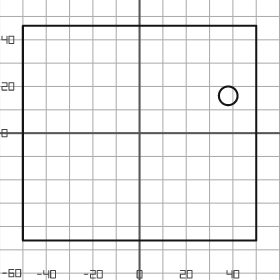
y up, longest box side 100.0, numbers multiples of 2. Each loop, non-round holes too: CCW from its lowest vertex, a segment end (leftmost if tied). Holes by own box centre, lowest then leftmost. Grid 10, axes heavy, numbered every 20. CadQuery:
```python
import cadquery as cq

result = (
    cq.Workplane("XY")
    .moveTo(-50.0, -46.0)
    .lineTo(50.0, -46.0)
    .lineTo(50.0, 46.0)
    .lineTo(-50.0, 46.0)
    .close()
    .moveTo(38.0, 16.0)
    .circle(4.0)
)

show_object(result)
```